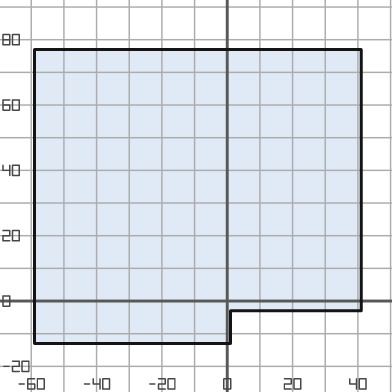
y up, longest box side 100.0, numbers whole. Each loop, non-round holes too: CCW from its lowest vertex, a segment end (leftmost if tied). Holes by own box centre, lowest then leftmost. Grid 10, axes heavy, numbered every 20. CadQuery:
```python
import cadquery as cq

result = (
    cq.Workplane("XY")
    .moveTo(-59.0, -13.0)
    .lineTo(1.0, -13.0)
    .lineTo(1.0, -3.0)
    .lineTo(41.0, -3.0)
    .lineTo(41.0, 77.0)
    .lineTo(-59.0, 77.0)
    .close()
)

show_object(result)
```